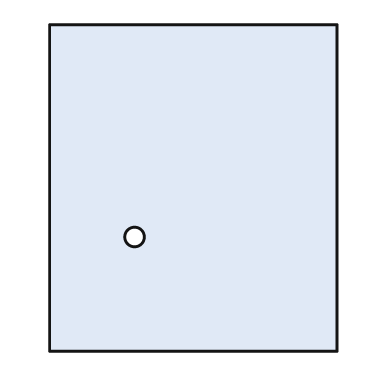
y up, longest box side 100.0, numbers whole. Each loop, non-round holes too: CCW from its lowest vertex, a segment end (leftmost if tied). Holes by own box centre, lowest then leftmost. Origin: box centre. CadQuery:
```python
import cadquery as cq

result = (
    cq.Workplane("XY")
    .moveTo(-44.0, -50.0)
    .lineTo(44.0, -50.0)
    .lineTo(44.0, 50.0)
    .lineTo(-44.0, 50.0)
    .close()
    .moveTo(-18.0, -15.0)
    .circle(3.0)
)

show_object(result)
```